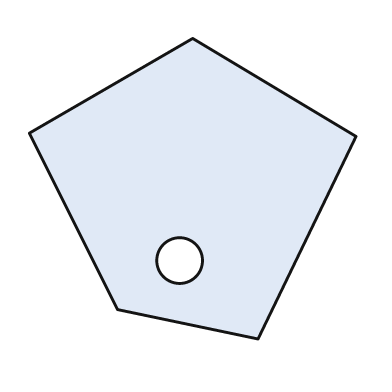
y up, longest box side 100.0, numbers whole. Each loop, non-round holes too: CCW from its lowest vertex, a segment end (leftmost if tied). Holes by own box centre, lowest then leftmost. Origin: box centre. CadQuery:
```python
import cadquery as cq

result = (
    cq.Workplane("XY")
    .moveTo(20.0, -46.0)
    .lineTo(50.0, 16.0)
    .lineTo(0.0, 46.0)
    .lineTo(-50.0, 17.0)
    .lineTo(-23.0, -37.0)
    .close()
    .moveTo(-4.0, -22.0)
    .circle(7.0)
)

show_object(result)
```